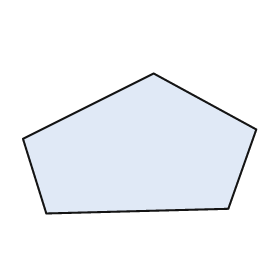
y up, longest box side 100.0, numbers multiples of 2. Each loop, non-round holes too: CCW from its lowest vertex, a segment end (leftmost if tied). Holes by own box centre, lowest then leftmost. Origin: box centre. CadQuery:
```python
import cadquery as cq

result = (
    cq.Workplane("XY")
    .moveTo(-40.0, -30.0)
    .lineTo(38.0, -28.0)
    .lineTo(50.0, 6.0)
    .lineTo(6.0, 30.0)
    .lineTo(-50.0, 2.0)
    .close()
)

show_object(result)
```